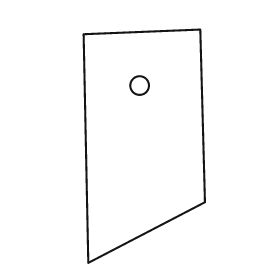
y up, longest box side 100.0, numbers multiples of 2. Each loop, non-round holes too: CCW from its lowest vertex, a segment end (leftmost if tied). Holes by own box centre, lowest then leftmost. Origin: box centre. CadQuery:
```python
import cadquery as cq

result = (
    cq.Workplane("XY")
    .moveTo(-24.0, -50.0)
    .lineTo(26.0, -24.0)
    .lineTo(24.0, 50.0)
    .lineTo(-26.0, 48.0)
    .close()
    .moveTo(-2.0, 26.0)
    .circle(4.0)
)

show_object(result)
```